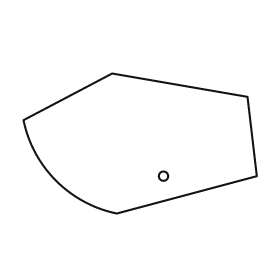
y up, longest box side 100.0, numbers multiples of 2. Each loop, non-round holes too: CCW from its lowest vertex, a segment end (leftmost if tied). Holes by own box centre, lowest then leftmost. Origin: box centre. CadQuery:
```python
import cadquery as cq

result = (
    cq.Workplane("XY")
    .moveTo(-10.0, -30.0)
    .lineTo(50.0, -14.0)
    .lineTo(46.0, 20.0)
    .lineTo(-12.0, 30.0)
    .lineTo(-50.0, 10.0)
    .threePointArc((-36.0, -16.0), (-10.0, -30.0))
    .close()
    .moveTo(10.0, -14.0)
    .circle(2.0)
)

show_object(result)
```